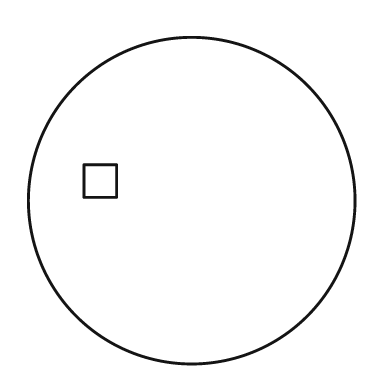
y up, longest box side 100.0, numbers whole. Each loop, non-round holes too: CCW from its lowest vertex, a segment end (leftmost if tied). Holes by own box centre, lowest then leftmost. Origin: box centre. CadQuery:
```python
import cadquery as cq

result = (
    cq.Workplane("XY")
    .moveTo(0.0, 0.0)
    .circle(50.0)
    .moveTo(-33.0, 1.0)
    .lineTo(-23.0, 1.0)
    .lineTo(-23.0, 11.0)
    .lineTo(-33.0, 11.0)
    .close()
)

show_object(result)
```